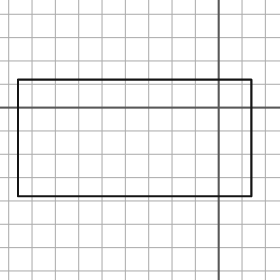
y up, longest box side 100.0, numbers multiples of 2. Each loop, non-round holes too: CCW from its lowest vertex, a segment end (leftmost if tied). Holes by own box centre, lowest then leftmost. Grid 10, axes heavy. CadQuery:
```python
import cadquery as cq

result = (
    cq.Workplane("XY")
    .moveTo(-86.0, -38.0)
    .lineTo(14.0, -38.0)
    .lineTo(14.0, 12.0)
    .lineTo(-86.0, 12.0)
    .close()
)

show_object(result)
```